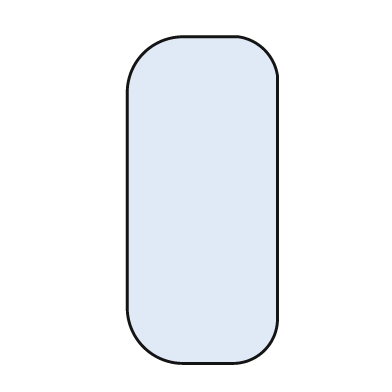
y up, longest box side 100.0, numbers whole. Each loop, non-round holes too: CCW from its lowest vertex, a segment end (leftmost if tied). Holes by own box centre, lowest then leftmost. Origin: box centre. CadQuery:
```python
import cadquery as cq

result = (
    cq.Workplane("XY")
    .moveTo(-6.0, -50.0)
    .lineTo(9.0, -50.0)
    .threePointArc((19.0, -46.0), (23.0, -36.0))
    .lineTo(23.0, 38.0)
    .threePointArc((19.0, 46.0), (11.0, 50.0))
    .lineTo(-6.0, 50.0)
    .threePointArc((-18.0, 45.0), (-23.0, 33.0))
    .lineTo(-23.0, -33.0)
    .threePointArc((-18.0, -45.0), (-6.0, -50.0))
    .close()
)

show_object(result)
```